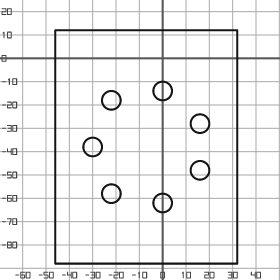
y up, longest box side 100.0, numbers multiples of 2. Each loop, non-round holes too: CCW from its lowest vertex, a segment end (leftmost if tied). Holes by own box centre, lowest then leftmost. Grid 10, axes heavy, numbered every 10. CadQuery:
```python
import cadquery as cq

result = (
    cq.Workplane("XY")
    .moveTo(-46.0, -88.0)
    .lineTo(32.0, -88.0)
    .lineTo(32.0, 12.0)
    .lineTo(-46.0, 12.0)
    .close()
    .moveTo(0.0, -62.0)
    .circle(4.0)
    .moveTo(-22.0, -58.0)
    .circle(4.0)
    .moveTo(16.0, -48.0)
    .circle(4.0)
    .moveTo(-30.0, -38.0)
    .circle(4.0)
    .moveTo(16.0, -28.0)
    .circle(4.0)
    .moveTo(-22.0, -18.0)
    .circle(4.0)
    .moveTo(0.0, -14.0)
    .circle(4.0)
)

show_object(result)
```